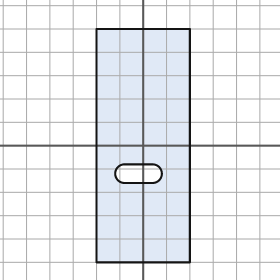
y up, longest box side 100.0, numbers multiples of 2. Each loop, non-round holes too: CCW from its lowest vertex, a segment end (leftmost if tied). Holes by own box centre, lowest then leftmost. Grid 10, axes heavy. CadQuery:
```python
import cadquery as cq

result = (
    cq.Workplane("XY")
    .moveTo(-20.0, -50.0)
    .lineTo(20.0, -50.0)
    .lineTo(20.0, 50.0)
    .lineTo(-20.0, 50.0)
    .close()
    .moveTo(-8.0, -16.0)
    .lineTo(4.0, -16.0)
    .threePointArc((8.0, -12.0), (4.0, -8.0))
    .lineTo(-8.0, -8.0)
    .threePointArc((-12.0, -12.0), (-8.0, -16.0))
    .close()
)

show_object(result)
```